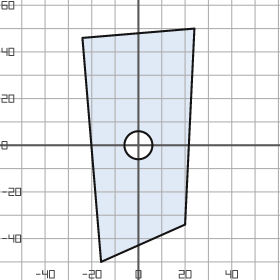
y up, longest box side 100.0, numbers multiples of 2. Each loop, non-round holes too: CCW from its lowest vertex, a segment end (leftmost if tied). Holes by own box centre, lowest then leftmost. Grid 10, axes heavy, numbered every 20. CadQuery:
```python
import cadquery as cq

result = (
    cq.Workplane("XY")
    .moveTo(-16.0, -50.0)
    .lineTo(20.0, -34.0)
    .lineTo(24.0, 50.0)
    .lineTo(-24.0, 46.0)
    .close()
    .moveTo(0.0, 0.0)
    .circle(6.0)
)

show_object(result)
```